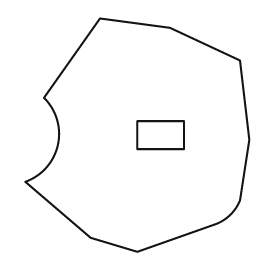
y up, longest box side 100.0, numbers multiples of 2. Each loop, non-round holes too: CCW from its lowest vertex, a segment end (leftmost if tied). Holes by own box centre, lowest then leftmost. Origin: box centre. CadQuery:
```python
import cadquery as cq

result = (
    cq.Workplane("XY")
    .moveTo(0.0, -50.0)
    .lineTo(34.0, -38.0)
    .threePointArc((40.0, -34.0), (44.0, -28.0))
    .lineTo(48.0, -2.0)
    .lineTo(44.0, 32.0)
    .lineTo(14.0, 46.0)
    .lineTo(-16.0, 50.0)
    .lineTo(-40.0, 16.0)
    .threePointArc((-34.0, -4.0), (-48.0, -20.0))
    .lineTo(-20.0, -44.0)
    .close()
    .moveTo(0.0, -6.0)
    .lineTo(20.0, -6.0)
    .lineTo(20.0, 6.0)
    .lineTo(0.0, 6.0)
    .close()
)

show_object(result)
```